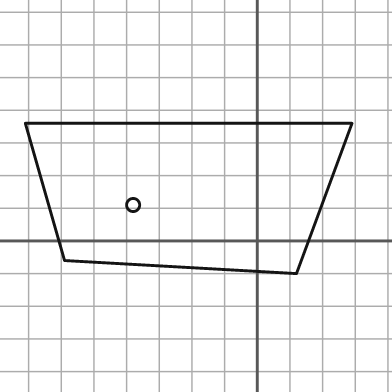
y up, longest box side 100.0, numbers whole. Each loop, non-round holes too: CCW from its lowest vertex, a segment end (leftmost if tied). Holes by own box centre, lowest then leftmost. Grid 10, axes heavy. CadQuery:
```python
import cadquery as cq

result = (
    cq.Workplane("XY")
    .moveTo(12.0, -10.0)
    .lineTo(29.0, 36.0)
    .lineTo(-71.0, 36.0)
    .lineTo(-59.0, -6.0)
    .close()
    .moveTo(-38.0, 11.0)
    .circle(2.0)
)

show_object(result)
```